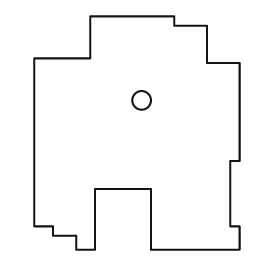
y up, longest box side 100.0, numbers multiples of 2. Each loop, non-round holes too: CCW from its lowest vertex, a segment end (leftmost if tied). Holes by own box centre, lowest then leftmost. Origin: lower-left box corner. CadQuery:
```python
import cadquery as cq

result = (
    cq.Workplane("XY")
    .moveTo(18.0, 0.0)
    .lineTo(26.0, 0.0)
    .lineTo(26.0, 26.0)
    .lineTo(50.0, 26.0)
    .lineTo(50.0, 0.0)
    .lineTo(88.0, 0.0)
    .lineTo(88.0, 10.0)
    .lineTo(84.0, 10.0)
    .lineTo(84.0, 38.0)
    .lineTo(88.0, 38.0)
    .lineTo(88.0, 80.0)
    .lineTo(74.0, 80.0)
    .lineTo(74.0, 96.0)
    .lineTo(60.0, 96.0)
    .lineTo(60.0, 100.0)
    .lineTo(24.0, 100.0)
    .lineTo(24.0, 82.0)
    .lineTo(0.0, 82.0)
    .lineTo(0.0, 10.0)
    .lineTo(8.0, 10.0)
    .lineTo(8.0, 6.0)
    .lineTo(18.0, 6.0)
    .close()
    .moveTo(46.0, 64.0)
    .circle(4.0)
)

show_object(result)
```